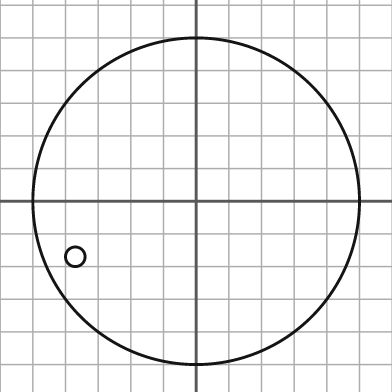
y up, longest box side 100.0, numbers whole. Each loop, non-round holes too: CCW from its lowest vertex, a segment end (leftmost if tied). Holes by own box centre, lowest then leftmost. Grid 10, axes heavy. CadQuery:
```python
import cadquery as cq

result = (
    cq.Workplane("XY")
    .moveTo(0.0, 0.0)
    .circle(50.0)
    .moveTo(-37.0, -17.0)
    .circle(3.0)
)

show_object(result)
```